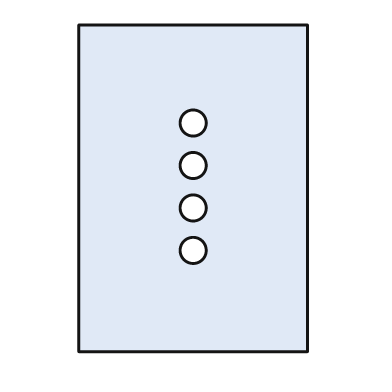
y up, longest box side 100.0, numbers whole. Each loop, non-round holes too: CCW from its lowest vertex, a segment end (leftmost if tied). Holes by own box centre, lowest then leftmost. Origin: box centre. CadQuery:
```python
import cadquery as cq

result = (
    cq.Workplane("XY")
    .moveTo(-35.0, -50.0)
    .lineTo(35.0, -50.0)
    .lineTo(35.0, 50.0)
    .lineTo(-35.0, 50.0)
    .close()
    .moveTo(0.0, -19.0)
    .circle(4.0)
    .moveTo(0.0, -6.0)
    .circle(4.0)
    .moveTo(0.0, 7.0)
    .circle(4.0)
    .moveTo(0.0, 20.0)
    .circle(4.0)
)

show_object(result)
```